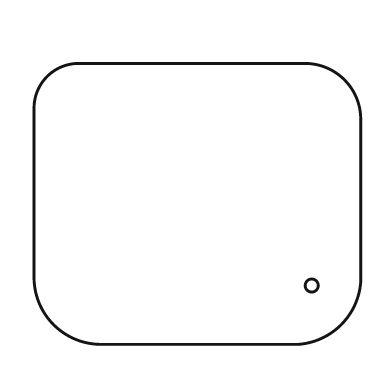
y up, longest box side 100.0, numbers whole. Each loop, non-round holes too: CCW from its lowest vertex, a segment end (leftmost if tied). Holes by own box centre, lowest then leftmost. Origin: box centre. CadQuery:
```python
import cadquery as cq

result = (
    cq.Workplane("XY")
    .moveTo(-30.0, -43.0)
    .lineTo(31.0, -43.0)
    .threePointArc((44.0, -37.0), (50.0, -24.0))
    .lineTo(50.0, 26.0)
    .threePointArc((45.0, 38.0), (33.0, 43.0))
    .lineTo(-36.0, 43.0)
    .threePointArc((-46.0, 39.0), (-50.0, 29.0))
    .lineTo(-50.0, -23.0)
    .threePointArc((-44.0, -37.0), (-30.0, -43.0))
    .close()
    .moveTo(35.0, -25.0)
    .circle(2.0)
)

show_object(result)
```